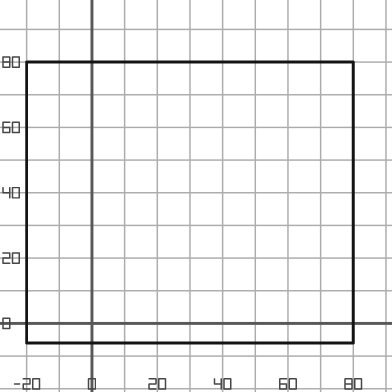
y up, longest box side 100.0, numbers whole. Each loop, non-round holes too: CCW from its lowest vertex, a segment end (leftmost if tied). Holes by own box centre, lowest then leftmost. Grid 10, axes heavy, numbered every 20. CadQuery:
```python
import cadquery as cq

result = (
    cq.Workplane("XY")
    .moveTo(-20.0, -6.0)
    .lineTo(80.0, -6.0)
    .lineTo(80.0, 80.0)
    .lineTo(-20.0, 80.0)
    .close()
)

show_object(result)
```